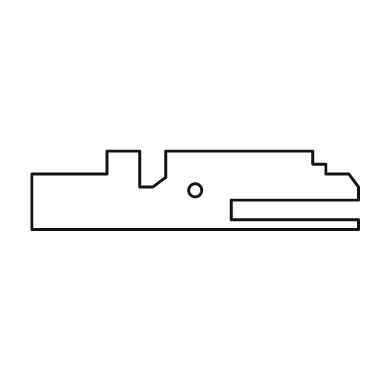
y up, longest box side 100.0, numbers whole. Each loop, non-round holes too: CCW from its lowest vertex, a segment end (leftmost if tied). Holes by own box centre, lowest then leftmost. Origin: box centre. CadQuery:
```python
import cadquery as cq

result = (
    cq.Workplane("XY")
    .moveTo(-50.0, -12.0)
    .lineTo(50.0, -12.0)
    .lineTo(50.0, -9.0)
    .lineTo(11.0, -9.0)
    .lineTo(11.0, -3.0)
    .lineTo(50.0, -3.0)
    .lineTo(50.0, 1.0)
    .lineTo(47.0, 5.0)
    .lineTo(40.0, 5.0)
    .lineTo(40.0, 8.0)
    .lineTo(36.0, 8.0)
    .lineTo(36.0, 12.0)
    .lineTo(-9.0, 12.0)
    .lineTo(-9.0, 4.0)
    .lineTo(-13.0, 1.0)
    .lineTo(-17.0, 1.0)
    .lineTo(-17.0, 12.0)
    .lineTo(-27.0, 12.0)
    .lineTo(-27.0, 5.0)
    .lineTo(-50.0, 5.0)
    .close()
    .moveTo(0.0, 0.0)
    .circle(2.0)
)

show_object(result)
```